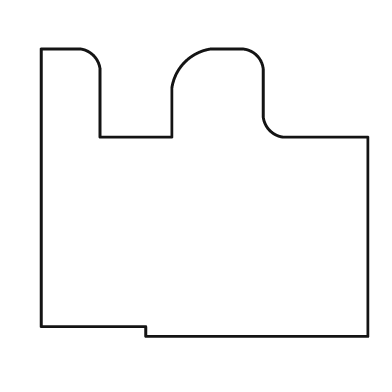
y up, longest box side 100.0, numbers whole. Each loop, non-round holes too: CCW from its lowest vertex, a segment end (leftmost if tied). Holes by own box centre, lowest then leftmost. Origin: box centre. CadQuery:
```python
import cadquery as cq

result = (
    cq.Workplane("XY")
    .moveTo(-18.0, -44.0)
    .lineTo(50.0, -44.0)
    .lineTo(50.0, 17.0)
    .lineTo(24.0, 17.0)
    .threePointArc((20.0, 19.0), (18.0, 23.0))
    .lineTo(18.0, 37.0)
    .threePointArc((16.0, 42.0), (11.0, 44.0))
    .lineTo(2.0, 44.0)
    .threePointArc((-6.0, 40.0), (-10.0, 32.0))
    .lineTo(-10.0, 17.0)
    .lineTo(-32.0, 17.0)
    .lineTo(-32.0, 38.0)
    .threePointArc((-34.0, 42.0), (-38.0, 44.0))
    .lineTo(-50.0, 44.0)
    .lineTo(-50.0, -41.0)
    .lineTo(-18.0, -41.0)
    .close()
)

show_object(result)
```